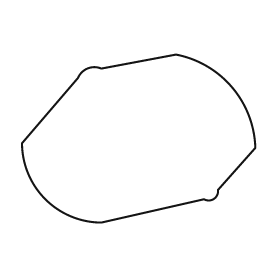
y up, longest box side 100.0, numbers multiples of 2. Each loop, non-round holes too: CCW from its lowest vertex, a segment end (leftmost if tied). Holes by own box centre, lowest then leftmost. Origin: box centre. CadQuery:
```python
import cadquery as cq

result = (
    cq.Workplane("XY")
    .moveTo(-16.0, -36.0)
    .lineTo(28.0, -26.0)
    .threePointArc((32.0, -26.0), (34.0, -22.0))
    .lineTo(50.0, -4.0)
    .threePointArc((40.0, 22.0), (16.0, 36.0))
    .lineTo(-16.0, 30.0)
    .threePointArc((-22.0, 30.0), (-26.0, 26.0))
    .lineTo(-50.0, -2.0)
    .threePointArc((-40.0, -26.0), (-16.0, -36.0))
    .close()
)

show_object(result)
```